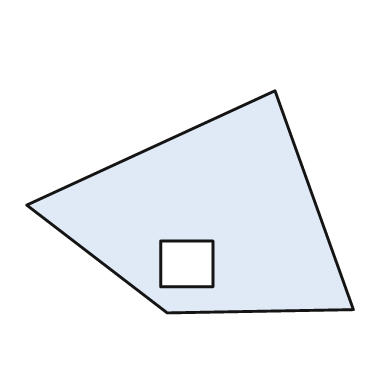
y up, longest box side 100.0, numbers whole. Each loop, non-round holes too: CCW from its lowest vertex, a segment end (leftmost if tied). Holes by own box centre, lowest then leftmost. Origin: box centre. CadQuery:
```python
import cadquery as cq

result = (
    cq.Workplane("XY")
    .moveTo(-7.0, -34.0)
    .lineTo(50.0, -33.0)
    .lineTo(26.0, 34.0)
    .lineTo(-50.0, -1.0)
    .close()
    .moveTo(-9.0, -26.0)
    .lineTo(7.0, -26.0)
    .lineTo(7.0, -12.0)
    .lineTo(-9.0, -12.0)
    .close()
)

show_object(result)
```